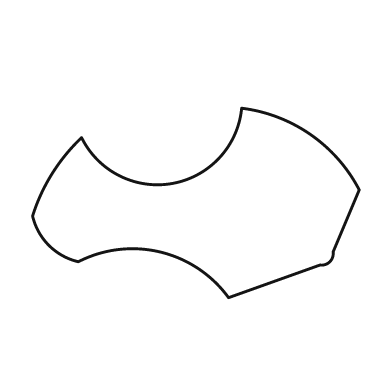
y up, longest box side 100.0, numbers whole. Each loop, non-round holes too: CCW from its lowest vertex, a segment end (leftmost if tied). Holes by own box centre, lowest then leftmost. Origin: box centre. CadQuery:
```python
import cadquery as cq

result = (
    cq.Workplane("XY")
    .moveTo(10.0, -29.0)
    .lineTo(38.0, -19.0)
    .threePointArc((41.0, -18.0), (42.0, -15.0))
    .lineTo(50.0, 4.0)
    .threePointArc((35.0, 21.0), (14.0, 29.0))
    .threePointArc((-7.0, 6.0), (-35.0, 20.0))
    .threePointArc((-44.0, 9.0), (-50.0, -4.0))
    .threePointArc((-45.0, -13.0), (-36.0, -18.0))
    .threePointArc((-11.0, -15.0), (10.0, -29.0))
    .close()
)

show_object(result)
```